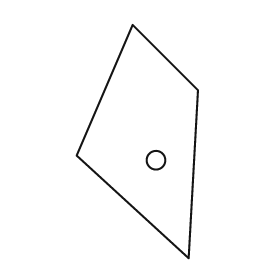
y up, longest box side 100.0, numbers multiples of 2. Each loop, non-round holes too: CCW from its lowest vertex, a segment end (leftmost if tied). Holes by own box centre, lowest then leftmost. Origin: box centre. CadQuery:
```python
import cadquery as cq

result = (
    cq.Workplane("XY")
    .moveTo(22.0, -50.0)
    .lineTo(26.0, 22.0)
    .lineTo(-2.0, 50.0)
    .lineTo(-26.0, -6.0)
    .close()
    .moveTo(8.0, -8.0)
    .circle(4.0)
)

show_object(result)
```